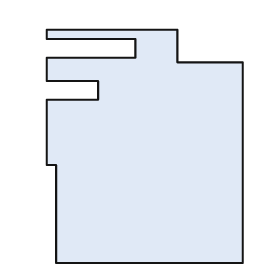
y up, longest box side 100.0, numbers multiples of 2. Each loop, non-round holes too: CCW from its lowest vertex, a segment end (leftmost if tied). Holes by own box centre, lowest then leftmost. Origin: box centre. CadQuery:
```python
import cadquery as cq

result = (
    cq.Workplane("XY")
    .moveTo(-38.0, -50.0)
    .lineTo(42.0, -50.0)
    .lineTo(42.0, 36.0)
    .lineTo(14.0, 36.0)
    .lineTo(14.0, 50.0)
    .lineTo(-42.0, 50.0)
    .lineTo(-42.0, 46.0)
    .lineTo(-4.0, 46.0)
    .lineTo(-4.0, 38.0)
    .lineTo(-42.0, 38.0)
    .lineTo(-42.0, 28.0)
    .lineTo(-20.0, 28.0)
    .lineTo(-20.0, 20.0)
    .lineTo(-42.0, 20.0)
    .lineTo(-42.0, -8.0)
    .lineTo(-38.0, -8.0)
    .close()
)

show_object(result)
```